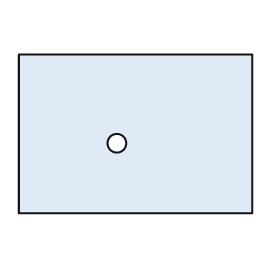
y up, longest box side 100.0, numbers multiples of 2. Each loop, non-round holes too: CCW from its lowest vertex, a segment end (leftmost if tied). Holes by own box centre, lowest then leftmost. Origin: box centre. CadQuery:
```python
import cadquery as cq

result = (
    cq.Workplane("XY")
    .moveTo(-50.0, -34.0)
    .lineTo(50.0, -34.0)
    .lineTo(50.0, 34.0)
    .lineTo(-50.0, 34.0)
    .close()
    .moveTo(-8.0, -4.0)
    .circle(4.0)
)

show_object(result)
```